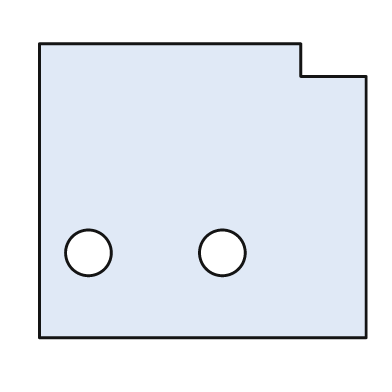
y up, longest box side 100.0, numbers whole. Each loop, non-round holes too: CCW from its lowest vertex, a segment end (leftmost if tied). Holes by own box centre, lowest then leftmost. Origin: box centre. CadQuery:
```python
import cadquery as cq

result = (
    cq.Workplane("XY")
    .moveTo(-50.0, -45.0)
    .lineTo(50.0, -45.0)
    .lineTo(50.0, 35.0)
    .lineTo(30.0, 35.0)
    .lineTo(30.0, 45.0)
    .lineTo(-50.0, 45.0)
    .close()
    .moveTo(-35.0, -19.0)
    .circle(7.0)
    .moveTo(6.0, -19.0)
    .circle(7.0)
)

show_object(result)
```